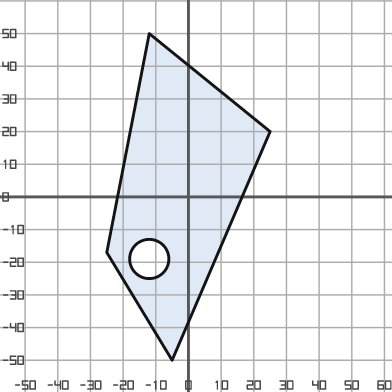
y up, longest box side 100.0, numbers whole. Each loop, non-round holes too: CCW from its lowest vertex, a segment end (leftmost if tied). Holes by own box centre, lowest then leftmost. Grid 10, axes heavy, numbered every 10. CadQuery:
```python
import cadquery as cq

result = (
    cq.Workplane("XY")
    .moveTo(-5.0, -50.0)
    .lineTo(25.0, 20.0)
    .lineTo(-12.0, 50.0)
    .lineTo(-25.0, -17.0)
    .close()
    .moveTo(-12.0, -19.0)
    .circle(6.0)
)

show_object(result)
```